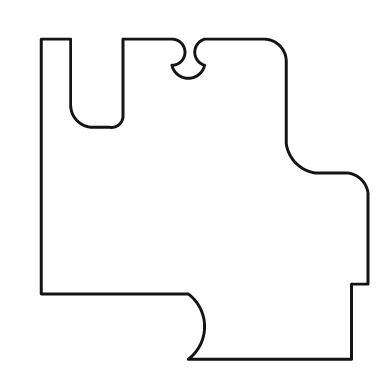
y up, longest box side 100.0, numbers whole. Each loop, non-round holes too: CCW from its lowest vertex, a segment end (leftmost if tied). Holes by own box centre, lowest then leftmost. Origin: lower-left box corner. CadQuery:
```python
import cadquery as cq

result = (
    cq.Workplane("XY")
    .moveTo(45.0, 0.0)
    .lineTo(95.0, 0.0)
    .lineTo(95.0, 23.0)
    .lineTo(100.0, 23.0)
    .lineTo(100.0, 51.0)
    .threePointArc((98.0, 55.0), (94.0, 57.0))
    .lineTo(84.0, 57.0)
    .threePointArc((78.0, 60.0), (75.0, 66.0))
    .lineTo(75.0, 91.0)
    .threePointArc((73.0, 96.0), (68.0, 98.0))
    .lineTo(50.0, 98.0)
    .threePointArc((47.0, 94.0), (50.0, 90.0))
    .threePointArc((45.0, 86.0), (40.0, 90.0))
    .threePointArc((44.0, 94.0), (40.0, 98.0))
    .lineTo(25.0, 98.0)
    .lineTo(25.0, 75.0)
    .threePointArc((24.0, 72.0), (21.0, 71.0))
    .lineTo(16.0, 71.0)
    .threePointArc((11.0, 73.0), (9.0, 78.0))
    .lineTo(9.0, 98.0)
    .lineTo(0.0, 98.0)
    .lineTo(0.0, 20.0)
    .lineTo(45.0, 20.0)
    .threePointArc((50.0, 10.0), (45.0, 0.0))
    .close()
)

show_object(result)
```